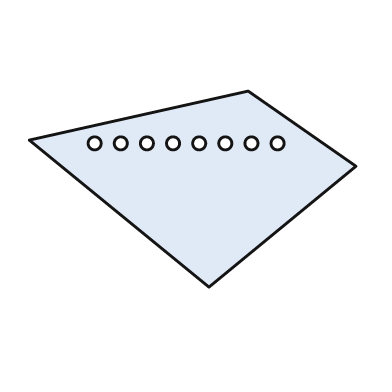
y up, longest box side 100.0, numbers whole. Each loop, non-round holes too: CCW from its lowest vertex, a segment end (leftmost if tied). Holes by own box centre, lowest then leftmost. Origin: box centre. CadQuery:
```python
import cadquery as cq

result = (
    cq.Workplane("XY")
    .moveTo(5.0, -30.0)
    .lineTo(50.0, 7.0)
    .lineTo(17.0, 30.0)
    .lineTo(-50.0, 15.0)
    .close()
    .moveTo(-30.0, 14.0)
    .circle(2.0)
    .moveTo(-22.0, 14.0)
    .circle(2.0)
    .moveTo(-14.0, 14.0)
    .circle(2.0)
    .moveTo(-6.0, 14.0)
    .circle(2.0)
    .moveTo(2.0, 14.0)
    .circle(2.0)
    .moveTo(10.0, 14.0)
    .circle(2.0)
    .moveTo(18.0, 14.0)
    .circle(2.0)
    .moveTo(26.0, 14.0)
    .circle(2.0)
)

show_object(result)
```